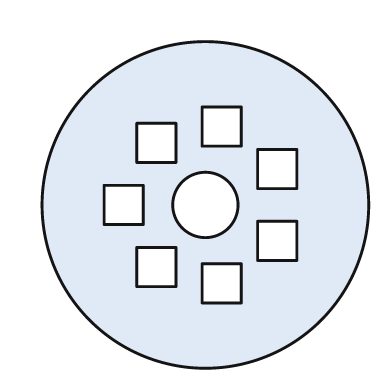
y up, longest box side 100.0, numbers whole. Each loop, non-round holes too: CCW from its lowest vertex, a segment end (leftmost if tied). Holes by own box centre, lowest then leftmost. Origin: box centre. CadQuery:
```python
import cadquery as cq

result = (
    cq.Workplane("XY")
    .moveTo(0.0, 0.0)
    .circle(50.0)
    .moveTo(-1.0, -30.0)
    .lineTo(11.0, -30.0)
    .lineTo(11.0, -18.0)
    .lineTo(-1.0, -18.0)
    .close()
    .moveTo(-21.0, -25.0)
    .lineTo(-9.0, -25.0)
    .lineTo(-9.0, -13.0)
    .lineTo(-21.0, -13.0)
    .close()
    .moveTo(16.0, -17.0)
    .lineTo(28.0, -17.0)
    .lineTo(28.0, -5.0)
    .lineTo(16.0, -5.0)
    .close()
    .moveTo(-31.0, -6.0)
    .lineTo(-19.0, -6.0)
    .lineTo(-19.0, 6.0)
    .lineTo(-31.0, 6.0)
    .close()
    .moveTo(0.0, 0.0)
    .circle(10.0)
    .moveTo(16.0, 5.0)
    .lineTo(28.0, 5.0)
    .lineTo(28.0, 17.0)
    .lineTo(16.0, 17.0)
    .close()
    .moveTo(-21.0, 13.0)
    .lineTo(-9.0, 13.0)
    .lineTo(-9.0, 25.0)
    .lineTo(-21.0, 25.0)
    .close()
    .moveTo(-1.0, 18.0)
    .lineTo(11.0, 18.0)
    .lineTo(11.0, 30.0)
    .lineTo(-1.0, 30.0)
    .close()
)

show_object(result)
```